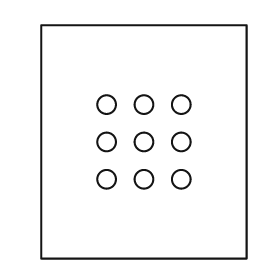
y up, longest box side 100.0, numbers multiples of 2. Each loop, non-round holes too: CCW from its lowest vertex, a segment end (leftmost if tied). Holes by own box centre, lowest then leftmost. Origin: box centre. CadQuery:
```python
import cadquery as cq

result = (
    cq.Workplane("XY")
    .moveTo(-44.0, -50.0)
    .lineTo(44.0, -50.0)
    .lineTo(44.0, 50.0)
    .lineTo(-44.0, 50.0)
    .close()
    .moveTo(-16.0, -16.0)
    .circle(4.0)
    .moveTo(0.0, -16.0)
    .circle(4.0)
    .moveTo(16.0, -16.0)
    .circle(4.0)
    .moveTo(-16.0, 0.0)
    .circle(4.0)
    .moveTo(0.0, 0.0)
    .circle(4.0)
    .moveTo(16.0, 0.0)
    .circle(4.0)
    .moveTo(-16.0, 16.0)
    .circle(4.0)
    .moveTo(0.0, 16.0)
    .circle(4.0)
    .moveTo(16.0, 16.0)
    .circle(4.0)
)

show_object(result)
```